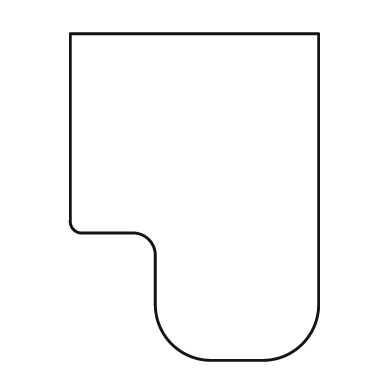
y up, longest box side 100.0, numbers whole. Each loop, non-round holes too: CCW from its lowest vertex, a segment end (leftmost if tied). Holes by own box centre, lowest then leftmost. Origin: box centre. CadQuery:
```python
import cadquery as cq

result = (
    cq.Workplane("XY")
    .moveTo(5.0, -50.0)
    .lineTo(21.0, -50.0)
    .threePointArc((33.0, -45.0), (38.0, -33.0))
    .lineTo(38.0, 50.0)
    .lineTo(-38.0, 50.0)
    .lineTo(-38.0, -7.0)
    .threePointArc((-37.0, -10.0), (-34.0, -11.0))
    .lineTo(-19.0, -11.0)
    .threePointArc((-14.0, -13.0), (-12.0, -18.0))
    .lineTo(-12.0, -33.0)
    .threePointArc((-7.0, -45.0), (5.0, -50.0))
    .close()
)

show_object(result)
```